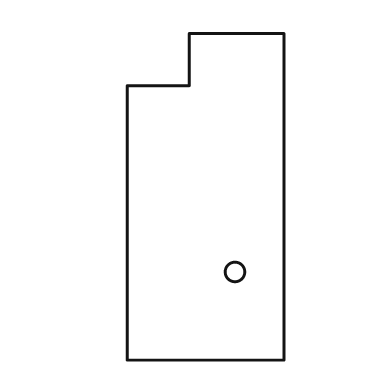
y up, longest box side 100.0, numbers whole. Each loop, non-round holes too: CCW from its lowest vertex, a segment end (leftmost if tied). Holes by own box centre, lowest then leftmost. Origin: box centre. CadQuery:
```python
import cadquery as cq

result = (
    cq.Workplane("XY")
    .moveTo(-24.0, -50.0)
    .lineTo(24.0, -50.0)
    .lineTo(24.0, 50.0)
    .lineTo(-5.0, 50.0)
    .lineTo(-5.0, 34.0)
    .lineTo(-24.0, 34.0)
    .close()
    .moveTo(9.0, -23.0)
    .circle(3.0)
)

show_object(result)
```